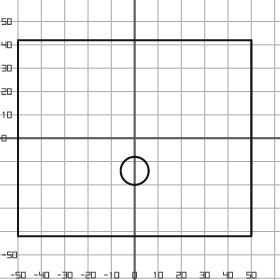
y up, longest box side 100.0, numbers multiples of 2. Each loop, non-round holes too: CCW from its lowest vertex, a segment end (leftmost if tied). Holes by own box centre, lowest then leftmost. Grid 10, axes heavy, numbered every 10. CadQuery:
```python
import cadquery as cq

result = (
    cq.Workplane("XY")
    .moveTo(-50.0, -42.0)
    .lineTo(50.0, -42.0)
    .lineTo(50.0, 42.0)
    .lineTo(-50.0, 42.0)
    .close()
    .moveTo(0.0, -14.0)
    .circle(6.0)
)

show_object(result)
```